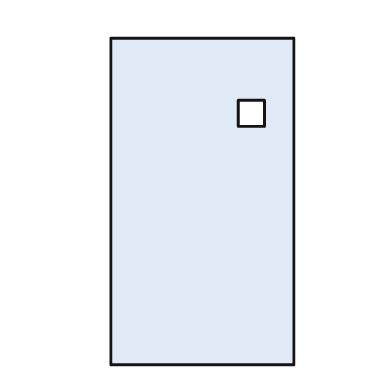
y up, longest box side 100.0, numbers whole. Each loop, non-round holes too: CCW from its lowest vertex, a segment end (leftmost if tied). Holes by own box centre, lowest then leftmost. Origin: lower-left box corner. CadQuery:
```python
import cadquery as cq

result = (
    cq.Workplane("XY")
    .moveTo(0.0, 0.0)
    .lineTo(56.0, 0.0)
    .lineTo(56.0, 100.0)
    .lineTo(0.0, 100.0)
    .close()
    .moveTo(39.0, 73.0)
    .lineTo(47.0, 73.0)
    .lineTo(47.0, 81.0)
    .lineTo(39.0, 81.0)
    .close()
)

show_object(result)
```